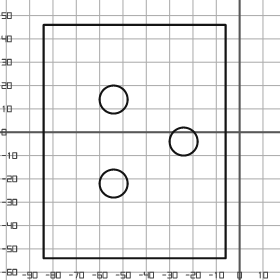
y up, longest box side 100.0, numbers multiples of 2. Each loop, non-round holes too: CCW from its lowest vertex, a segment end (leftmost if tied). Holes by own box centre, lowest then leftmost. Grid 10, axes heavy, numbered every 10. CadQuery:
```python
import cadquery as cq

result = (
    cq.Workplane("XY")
    .moveTo(-84.0, -54.0)
    .lineTo(-6.0, -54.0)
    .lineTo(-6.0, 46.0)
    .lineTo(-84.0, 46.0)
    .close()
    .moveTo(-54.0, -22.0)
    .circle(6.0)
    .moveTo(-24.0, -4.0)
    .circle(6.0)
    .moveTo(-54.0, 14.0)
    .circle(6.0)
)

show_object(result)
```